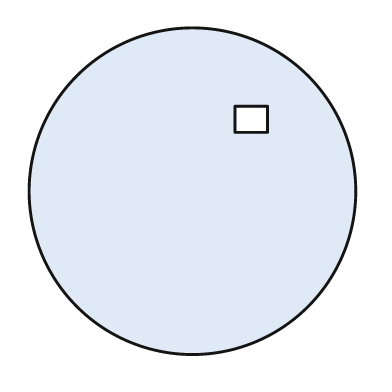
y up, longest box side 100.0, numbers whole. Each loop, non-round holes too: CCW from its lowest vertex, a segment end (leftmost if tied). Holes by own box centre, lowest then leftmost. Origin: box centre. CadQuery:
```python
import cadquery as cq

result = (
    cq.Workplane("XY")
    .moveTo(0.0, 0.0)
    .circle(50.0)
    .moveTo(13.0, 18.0)
    .lineTo(23.0, 18.0)
    .lineTo(23.0, 26.0)
    .lineTo(13.0, 26.0)
    .close()
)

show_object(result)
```